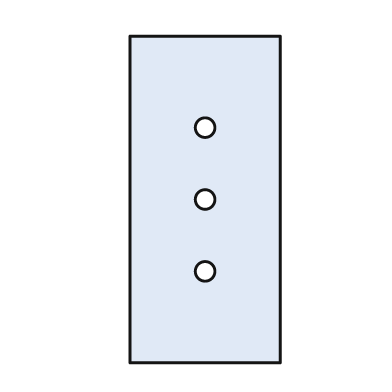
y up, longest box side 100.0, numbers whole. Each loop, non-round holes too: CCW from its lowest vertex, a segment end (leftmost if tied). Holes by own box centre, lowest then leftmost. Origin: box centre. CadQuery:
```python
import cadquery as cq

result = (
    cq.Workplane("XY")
    .moveTo(-23.0, -50.0)
    .lineTo(23.0, -50.0)
    .lineTo(23.0, 50.0)
    .lineTo(-23.0, 50.0)
    .close()
    .moveTo(0.0, -22.0)
    .circle(3.0)
    .moveTo(0.0, 0.0)
    .circle(3.0)
    .moveTo(0.0, 22.0)
    .circle(3.0)
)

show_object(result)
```